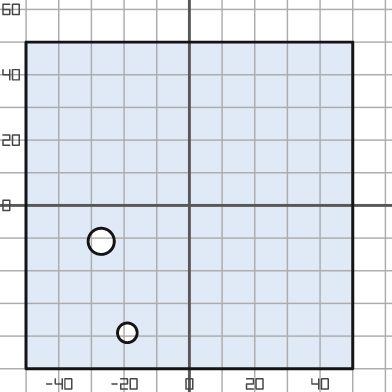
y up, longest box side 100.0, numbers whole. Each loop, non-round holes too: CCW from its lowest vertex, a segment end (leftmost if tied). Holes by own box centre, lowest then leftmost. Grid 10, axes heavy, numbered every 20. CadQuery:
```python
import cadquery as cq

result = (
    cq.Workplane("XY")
    .moveTo(-50.0, -50.0)
    .lineTo(50.0, -50.0)
    .lineTo(50.0, 50.0)
    .lineTo(-50.0, 50.0)
    .close()
    .moveTo(-19.0, -39.0)
    .circle(3.0)
    .moveTo(-27.0, -11.0)
    .circle(4.0)
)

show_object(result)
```